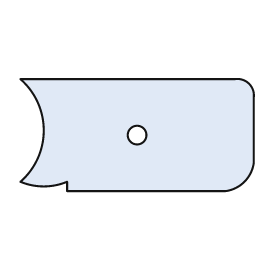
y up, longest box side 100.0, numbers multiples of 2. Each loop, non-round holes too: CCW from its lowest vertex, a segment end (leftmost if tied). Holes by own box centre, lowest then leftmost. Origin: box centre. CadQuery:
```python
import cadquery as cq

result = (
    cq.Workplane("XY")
    .moveTo(-30.0, -24.0)
    .lineTo(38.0, -24.0)
    .threePointArc((46.0, -20.0), (50.0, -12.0))
    .lineTo(50.0, 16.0)
    .threePointArc((48.0, 22.0), (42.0, 24.0))
    .lineTo(-50.0, 24.0)
    .threePointArc((-40.0, 2.0), (-50.0, -20.0))
    .threePointArc((-40.0, -22.0), (-30.0, -20.0))
    .close()
    .moveTo(0.0, 0.0)
    .circle(4.0)
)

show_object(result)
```